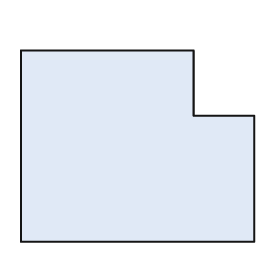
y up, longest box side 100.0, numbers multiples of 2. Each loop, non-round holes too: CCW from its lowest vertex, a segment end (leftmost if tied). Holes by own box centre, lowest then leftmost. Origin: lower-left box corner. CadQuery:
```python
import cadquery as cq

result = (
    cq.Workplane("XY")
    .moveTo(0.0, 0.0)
    .lineTo(100.0, 0.0)
    .lineTo(100.0, 54.0)
    .lineTo(74.0, 54.0)
    .lineTo(74.0, 82.0)
    .lineTo(0.0, 82.0)
    .close()
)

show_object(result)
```